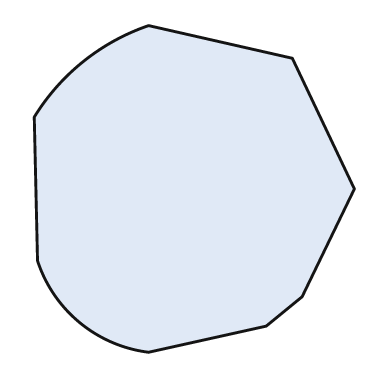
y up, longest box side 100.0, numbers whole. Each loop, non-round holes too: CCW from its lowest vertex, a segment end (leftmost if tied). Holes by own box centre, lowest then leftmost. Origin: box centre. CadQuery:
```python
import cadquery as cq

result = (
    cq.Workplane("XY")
    .moveTo(-14.0, -50.0)
    .lineTo(22.0, -42.0)
    .lineTo(33.0, -33.0)
    .lineTo(49.0, 0.0)
    .lineTo(30.0, 40.0)
    .lineTo(-14.0, 50.0)
    .threePointArc((-34.0, 39.0), (-49.0, 22.0))
    .lineTo(-48.0, -22.0)
    .threePointArc((-35.0, -41.0), (-14.0, -50.0))
    .close()
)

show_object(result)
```